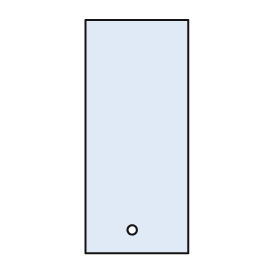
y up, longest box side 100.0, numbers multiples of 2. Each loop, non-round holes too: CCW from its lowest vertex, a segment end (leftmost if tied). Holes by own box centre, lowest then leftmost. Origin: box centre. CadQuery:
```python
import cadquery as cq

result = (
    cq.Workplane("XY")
    .moveTo(-22.0, -50.0)
    .lineTo(22.0, -50.0)
    .lineTo(22.0, 50.0)
    .lineTo(-22.0, 50.0)
    .close()
    .moveTo(-2.0, -40.0)
    .circle(2.0)
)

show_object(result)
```